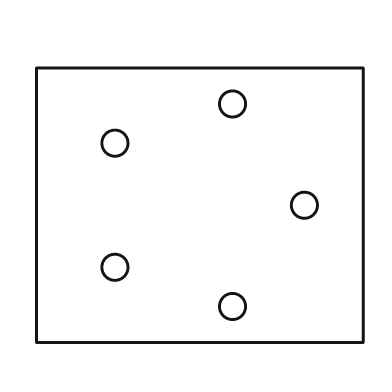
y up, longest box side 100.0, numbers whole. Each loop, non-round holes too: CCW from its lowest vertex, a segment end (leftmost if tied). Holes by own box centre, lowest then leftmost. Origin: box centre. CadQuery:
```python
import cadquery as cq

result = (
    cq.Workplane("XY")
    .moveTo(-50.0, -42.0)
    .lineTo(50.0, -42.0)
    .lineTo(50.0, 42.0)
    .lineTo(-50.0, 42.0)
    .close()
    .moveTo(10.0, -31.0)
    .circle(4.0)
    .moveTo(-26.0, -19.0)
    .circle(4.0)
    .moveTo(32.0, 0.0)
    .circle(4.0)
    .moveTo(-26.0, 19.0)
    .circle(4.0)
    .moveTo(10.0, 31.0)
    .circle(4.0)
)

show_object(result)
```